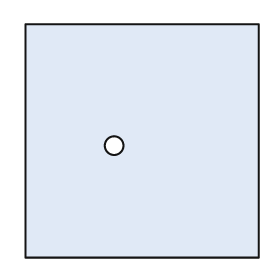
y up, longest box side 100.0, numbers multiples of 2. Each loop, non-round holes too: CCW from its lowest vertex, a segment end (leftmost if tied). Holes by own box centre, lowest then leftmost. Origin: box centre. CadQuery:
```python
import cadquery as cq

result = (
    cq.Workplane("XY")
    .moveTo(-50.0, -50.0)
    .lineTo(50.0, -50.0)
    .lineTo(50.0, 50.0)
    .lineTo(-50.0, 50.0)
    .close()
    .moveTo(-12.0, -2.0)
    .circle(4.0)
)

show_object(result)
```